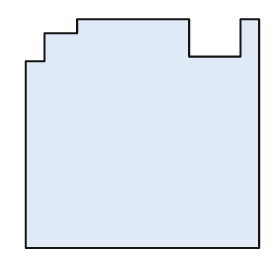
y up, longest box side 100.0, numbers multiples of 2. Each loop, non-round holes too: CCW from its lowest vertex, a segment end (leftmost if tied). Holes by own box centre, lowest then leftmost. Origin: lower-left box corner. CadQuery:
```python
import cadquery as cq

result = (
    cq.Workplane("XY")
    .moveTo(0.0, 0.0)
    .lineTo(100.0, 0.0)
    .lineTo(100.0, 98.0)
    .lineTo(92.0, 98.0)
    .lineTo(92.0, 82.0)
    .lineTo(70.0, 82.0)
    .lineTo(70.0, 98.0)
    .lineTo(22.0, 98.0)
    .lineTo(22.0, 92.0)
    .lineTo(8.0, 92.0)
    .lineTo(8.0, 80.0)
    .lineTo(0.0, 80.0)
    .close()
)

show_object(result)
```